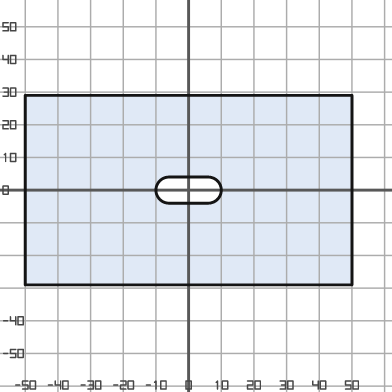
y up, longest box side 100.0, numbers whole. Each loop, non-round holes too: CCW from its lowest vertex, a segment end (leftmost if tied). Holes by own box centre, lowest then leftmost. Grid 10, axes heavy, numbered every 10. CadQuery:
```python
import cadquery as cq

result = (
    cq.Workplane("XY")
    .moveTo(-50.0, -29.0)
    .lineTo(50.0, -29.0)
    .lineTo(50.0, 29.0)
    .lineTo(-50.0, 29.0)
    .close()
    .moveTo(-6.0, -4.0)
    .lineTo(6.0, -4.0)
    .threePointArc((10.0, 0.0), (6.0, 4.0))
    .lineTo(-6.0, 4.0)
    .threePointArc((-10.0, 0.0), (-6.0, -4.0))
    .close()
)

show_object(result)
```